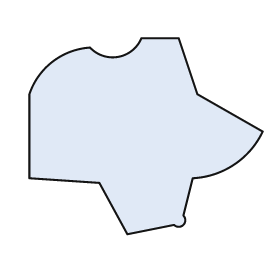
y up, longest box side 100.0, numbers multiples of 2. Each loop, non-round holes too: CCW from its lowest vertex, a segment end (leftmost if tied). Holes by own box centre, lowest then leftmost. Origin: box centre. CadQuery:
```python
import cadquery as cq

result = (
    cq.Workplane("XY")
    .moveTo(-8.0, -42.0)
    .lineTo(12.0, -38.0)
    .threePointArc((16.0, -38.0), (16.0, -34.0))
    .lineTo(20.0, -18.0)
    .threePointArc((38.0, -12.0), (50.0, 2.0))
    .lineTo(22.0, 18.0)
    .lineTo(14.0, 42.0)
    .lineTo(-2.0, 42.0)
    .threePointArc((-12.0, 34.0), (-24.0, 38.0))
    .threePointArc((-40.0, 32.0), (-50.0, 18.0))
    .lineTo(-50.0, -18.0)
    .lineTo(-20.0, -20.0)
    .close()
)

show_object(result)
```